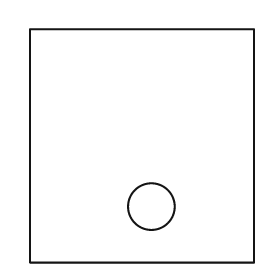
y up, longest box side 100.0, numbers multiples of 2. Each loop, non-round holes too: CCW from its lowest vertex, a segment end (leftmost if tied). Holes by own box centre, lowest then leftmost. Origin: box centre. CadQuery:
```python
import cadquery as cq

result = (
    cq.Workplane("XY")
    .moveTo(-48.0, -50.0)
    .lineTo(48.0, -50.0)
    .lineTo(48.0, 50.0)
    .lineTo(-48.0, 50.0)
    .close()
    .moveTo(4.0, -26.0)
    .circle(10.0)
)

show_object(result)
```